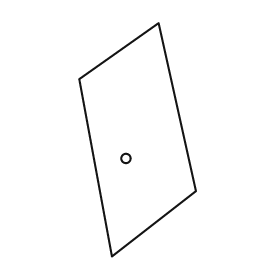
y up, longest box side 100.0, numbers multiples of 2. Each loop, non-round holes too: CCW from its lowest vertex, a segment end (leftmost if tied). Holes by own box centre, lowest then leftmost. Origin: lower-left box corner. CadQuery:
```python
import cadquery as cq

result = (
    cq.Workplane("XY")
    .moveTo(14.0, 0.0)
    .lineTo(50.0, 28.0)
    .lineTo(34.0, 100.0)
    .lineTo(0.0, 76.0)
    .close()
    .moveTo(20.0, 42.0)
    .circle(2.0)
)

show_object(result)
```